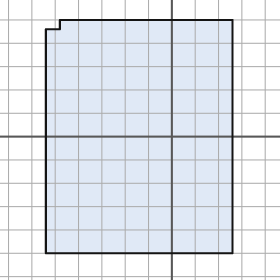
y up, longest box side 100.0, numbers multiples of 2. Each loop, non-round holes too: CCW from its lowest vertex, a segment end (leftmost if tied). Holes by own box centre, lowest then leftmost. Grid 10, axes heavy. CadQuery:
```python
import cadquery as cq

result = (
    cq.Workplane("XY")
    .moveTo(-54.0, -50.0)
    .lineTo(26.0, -50.0)
    .lineTo(26.0, 50.0)
    .lineTo(-48.0, 50.0)
    .lineTo(-48.0, 46.0)
    .lineTo(-54.0, 46.0)
    .close()
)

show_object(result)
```